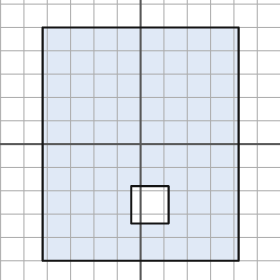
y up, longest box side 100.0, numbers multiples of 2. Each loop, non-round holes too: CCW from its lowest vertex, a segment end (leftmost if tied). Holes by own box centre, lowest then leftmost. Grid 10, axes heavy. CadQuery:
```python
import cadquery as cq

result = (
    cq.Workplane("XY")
    .moveTo(-42.0, -50.0)
    .lineTo(42.0, -50.0)
    .lineTo(42.0, 50.0)
    .lineTo(-42.0, 50.0)
    .close()
    .moveTo(-4.0, -34.0)
    .lineTo(12.0, -34.0)
    .lineTo(12.0, -18.0)
    .lineTo(-4.0, -18.0)
    .close()
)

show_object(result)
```